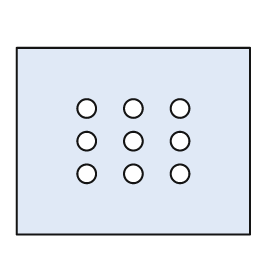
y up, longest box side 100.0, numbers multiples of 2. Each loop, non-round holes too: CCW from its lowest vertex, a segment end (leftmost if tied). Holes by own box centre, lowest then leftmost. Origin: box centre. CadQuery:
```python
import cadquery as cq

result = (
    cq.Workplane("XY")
    .moveTo(-50.0, -40.0)
    .lineTo(50.0, -40.0)
    .lineTo(50.0, 40.0)
    .lineTo(-50.0, 40.0)
    .close()
    .moveTo(-20.0, -14.0)
    .circle(4.0)
    .moveTo(0.0, -14.0)
    .circle(4.0)
    .moveTo(20.0, -14.0)
    .circle(4.0)
    .moveTo(-20.0, 0.0)
    .circle(4.0)
    .moveTo(0.0, 0.0)
    .circle(4.0)
    .moveTo(20.0, 0.0)
    .circle(4.0)
    .moveTo(-20.0, 14.0)
    .circle(4.0)
    .moveTo(0.0, 14.0)
    .circle(4.0)
    .moveTo(20.0, 14.0)
    .circle(4.0)
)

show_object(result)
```